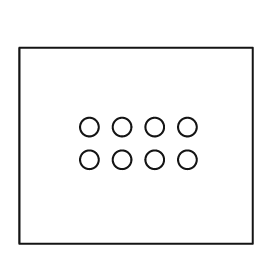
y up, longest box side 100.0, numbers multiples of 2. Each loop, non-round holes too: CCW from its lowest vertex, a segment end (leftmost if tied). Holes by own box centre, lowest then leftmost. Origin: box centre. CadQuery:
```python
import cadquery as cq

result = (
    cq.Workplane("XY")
    .moveTo(-50.0, -42.0)
    .lineTo(50.0, -42.0)
    .lineTo(50.0, 42.0)
    .lineTo(-50.0, 42.0)
    .close()
    .moveTo(-20.0, -6.0)
    .circle(4.0)
    .moveTo(-6.0, -6.0)
    .circle(4.0)
    .moveTo(8.0, -6.0)
    .circle(4.0)
    .moveTo(22.0, -6.0)
    .circle(4.0)
    .moveTo(-20.0, 8.0)
    .circle(4.0)
    .moveTo(-6.0, 8.0)
    .circle(4.0)
    .moveTo(8.0, 8.0)
    .circle(4.0)
    .moveTo(22.0, 8.0)
    .circle(4.0)
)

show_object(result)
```